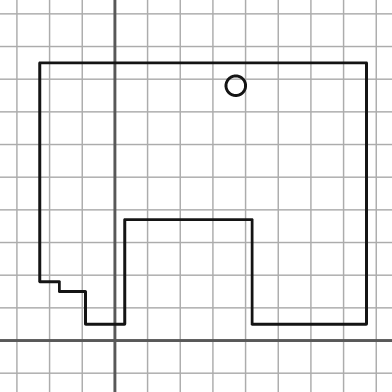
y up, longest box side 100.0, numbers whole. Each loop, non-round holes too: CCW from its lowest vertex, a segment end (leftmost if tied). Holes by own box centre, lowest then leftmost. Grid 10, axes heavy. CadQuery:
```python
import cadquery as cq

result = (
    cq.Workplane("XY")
    .moveTo(-9.0, 5.0)
    .lineTo(3.0, 5.0)
    .lineTo(3.0, 37.0)
    .lineTo(42.0, 37.0)
    .lineTo(42.0, 5.0)
    .lineTo(77.0, 5.0)
    .lineTo(77.0, 85.0)
    .lineTo(-23.0, 85.0)
    .lineTo(-23.0, 18.0)
    .lineTo(-17.0, 18.0)
    .lineTo(-17.0, 15.0)
    .lineTo(-9.0, 15.0)
    .close()
    .moveTo(37.0, 78.0)
    .circle(3.0)
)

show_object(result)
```